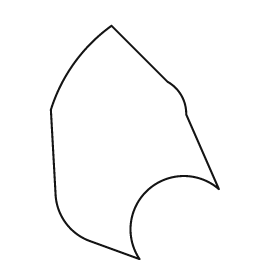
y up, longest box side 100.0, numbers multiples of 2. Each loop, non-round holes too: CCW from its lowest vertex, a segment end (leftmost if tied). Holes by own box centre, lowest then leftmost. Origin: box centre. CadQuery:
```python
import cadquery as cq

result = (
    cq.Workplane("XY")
    .moveTo(2.0, -50.0)
    .threePointArc((6.0, -20.0), (36.0, -20.0))
    .lineTo(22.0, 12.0)
    .threePointArc((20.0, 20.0), (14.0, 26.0))
    .lineTo(-10.0, 50.0)
    .threePointArc((-26.0, 34.0), (-36.0, 14.0))
    .lineTo(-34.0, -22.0)
    .threePointArc((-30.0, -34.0), (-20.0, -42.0))
    .close()
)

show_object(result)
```